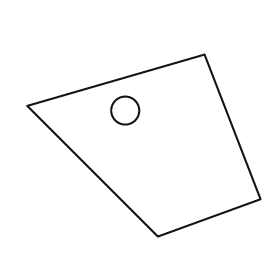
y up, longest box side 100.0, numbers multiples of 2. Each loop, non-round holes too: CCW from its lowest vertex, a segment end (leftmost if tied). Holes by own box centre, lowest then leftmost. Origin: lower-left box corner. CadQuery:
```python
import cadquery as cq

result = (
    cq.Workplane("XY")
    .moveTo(56.0, 0.0)
    .lineTo(100.0, 16.0)
    .lineTo(76.0, 78.0)
    .lineTo(0.0, 56.0)
    .close()
    .moveTo(42.0, 54.0)
    .circle(6.0)
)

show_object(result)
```